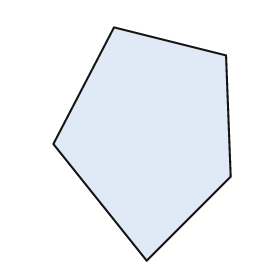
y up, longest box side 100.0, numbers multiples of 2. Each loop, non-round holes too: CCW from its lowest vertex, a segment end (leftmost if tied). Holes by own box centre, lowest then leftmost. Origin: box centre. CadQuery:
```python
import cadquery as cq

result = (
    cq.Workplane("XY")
    .moveTo(2.0, -50.0)
    .lineTo(38.0, -14.0)
    .lineTo(36.0, 38.0)
    .lineTo(-12.0, 50.0)
    .lineTo(-38.0, 0.0)
    .close()
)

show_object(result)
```